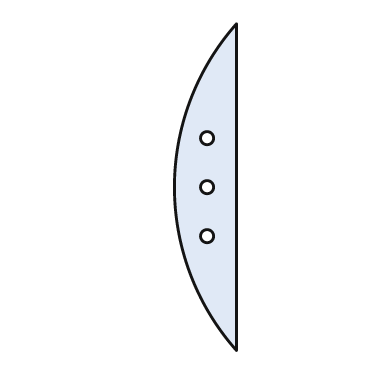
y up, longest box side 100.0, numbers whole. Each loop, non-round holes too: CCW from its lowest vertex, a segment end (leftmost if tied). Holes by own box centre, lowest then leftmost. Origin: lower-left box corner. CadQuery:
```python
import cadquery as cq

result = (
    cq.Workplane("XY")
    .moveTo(19.0, 0.0)
    .lineTo(19.0, 100.0)
    .threePointArc((0.0, 50.0), (19.0, 0.0))
    .close()
    .moveTo(10.0, 35.0)
    .circle(2.0)
    .moveTo(10.0, 50.0)
    .circle(2.0)
    .moveTo(10.0, 65.0)
    .circle(2.0)
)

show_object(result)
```